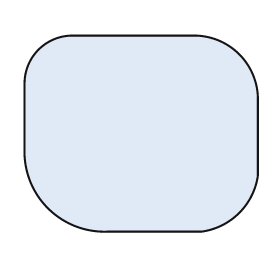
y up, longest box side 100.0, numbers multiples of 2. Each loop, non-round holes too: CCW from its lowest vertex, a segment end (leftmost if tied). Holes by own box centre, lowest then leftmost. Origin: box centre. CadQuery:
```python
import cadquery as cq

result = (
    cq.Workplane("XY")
    .moveTo(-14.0, -42.0)
    .lineTo(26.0, -42.0)
    .threePointArc((42.0, -34.0), (50.0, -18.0))
    .lineTo(50.0, 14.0)
    .threePointArc((42.0, 34.0), (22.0, 42.0))
    .lineTo(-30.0, 42.0)
    .threePointArc((-44.0, 36.0), (-50.0, 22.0))
    .lineTo(-50.0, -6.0)
    .threePointArc((-40.0, -32.0), (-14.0, -42.0))
    .close()
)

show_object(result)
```